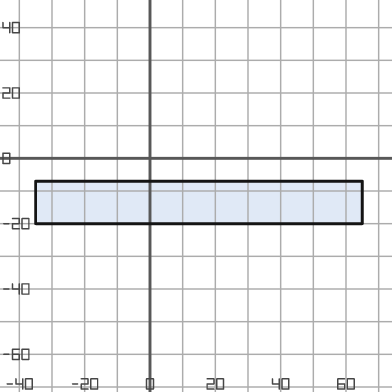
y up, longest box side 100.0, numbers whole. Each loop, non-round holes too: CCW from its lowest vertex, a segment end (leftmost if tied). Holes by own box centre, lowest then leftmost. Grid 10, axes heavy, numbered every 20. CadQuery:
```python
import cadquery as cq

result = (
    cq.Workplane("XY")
    .moveTo(-35.0, -20.0)
    .lineTo(65.0, -20.0)
    .lineTo(65.0, -7.0)
    .lineTo(-35.0, -7.0)
    .close()
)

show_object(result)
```